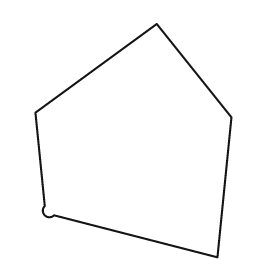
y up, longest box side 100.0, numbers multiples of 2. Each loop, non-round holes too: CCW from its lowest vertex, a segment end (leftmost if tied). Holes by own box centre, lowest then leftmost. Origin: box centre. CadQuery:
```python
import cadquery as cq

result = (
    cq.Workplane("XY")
    .moveTo(36.0, -50.0)
    .lineTo(42.0, 10.0)
    .lineTo(10.0, 50.0)
    .lineTo(-42.0, 12.0)
    .lineTo(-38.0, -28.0)
    .threePointArc((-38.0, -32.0), (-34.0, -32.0))
    .close()
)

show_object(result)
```